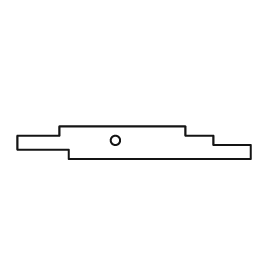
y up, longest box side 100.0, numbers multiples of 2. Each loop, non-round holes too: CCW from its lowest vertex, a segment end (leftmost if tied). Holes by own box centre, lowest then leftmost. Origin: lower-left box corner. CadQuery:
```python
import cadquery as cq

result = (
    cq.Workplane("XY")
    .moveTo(22.0, 0.0)
    .lineTo(100.0, 0.0)
    .lineTo(100.0, 6.0)
    .lineTo(84.0, 6.0)
    .lineTo(84.0, 10.0)
    .lineTo(72.0, 10.0)
    .lineTo(72.0, 14.0)
    .lineTo(18.0, 14.0)
    .lineTo(18.0, 10.0)
    .lineTo(0.0, 10.0)
    .lineTo(0.0, 4.0)
    .lineTo(22.0, 4.0)
    .close()
    .moveTo(42.0, 8.0)
    .circle(2.0)
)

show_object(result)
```